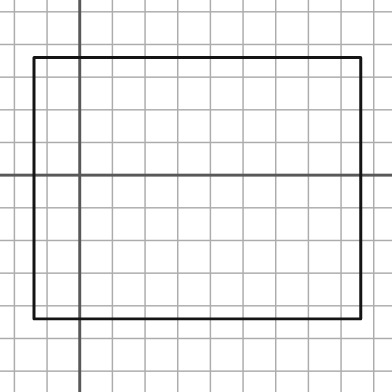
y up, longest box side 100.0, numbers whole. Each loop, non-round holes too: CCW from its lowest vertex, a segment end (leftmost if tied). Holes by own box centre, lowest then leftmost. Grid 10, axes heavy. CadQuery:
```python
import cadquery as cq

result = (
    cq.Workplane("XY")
    .moveTo(-14.0, -44.0)
    .lineTo(86.0, -44.0)
    .lineTo(86.0, 36.0)
    .lineTo(-14.0, 36.0)
    .close()
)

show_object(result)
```